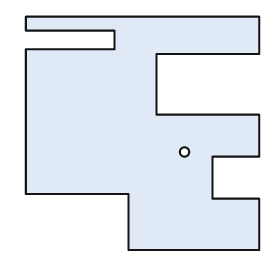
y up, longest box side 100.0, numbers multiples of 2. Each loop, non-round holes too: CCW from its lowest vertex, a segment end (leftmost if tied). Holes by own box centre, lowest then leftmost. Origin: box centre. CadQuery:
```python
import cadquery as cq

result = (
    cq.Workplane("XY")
    .moveTo(-6.0, -50.0)
    .lineTo(50.0, -50.0)
    .lineTo(50.0, -28.0)
    .lineTo(30.0, -28.0)
    .lineTo(30.0, -10.0)
    .lineTo(50.0, -10.0)
    .lineTo(50.0, 8.0)
    .lineTo(6.0, 8.0)
    .lineTo(6.0, 34.0)
    .lineTo(50.0, 34.0)
    .lineTo(50.0, 50.0)
    .lineTo(-50.0, 50.0)
    .lineTo(-50.0, 44.0)
    .lineTo(-12.0, 44.0)
    .lineTo(-12.0, 36.0)
    .lineTo(-50.0, 36.0)
    .lineTo(-50.0, -26.0)
    .lineTo(-6.0, -26.0)
    .close()
    .moveTo(18.0, -8.0)
    .circle(2.0)
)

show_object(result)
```